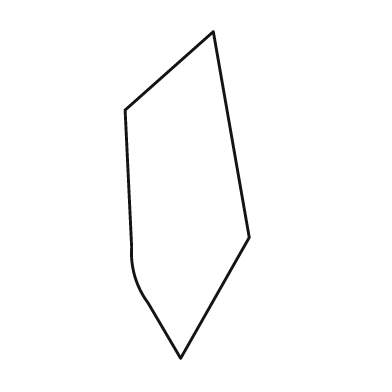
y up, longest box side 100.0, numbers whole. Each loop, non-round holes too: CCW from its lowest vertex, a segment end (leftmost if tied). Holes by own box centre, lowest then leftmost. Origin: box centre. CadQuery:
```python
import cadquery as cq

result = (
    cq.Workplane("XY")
    .moveTo(-2.0, -50.0)
    .lineTo(19.0, -13.0)
    .lineTo(8.0, 50.0)
    .lineTo(-19.0, 26.0)
    .lineTo(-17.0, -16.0)
    .threePointArc((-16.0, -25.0), (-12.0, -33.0))
    .close()
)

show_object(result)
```